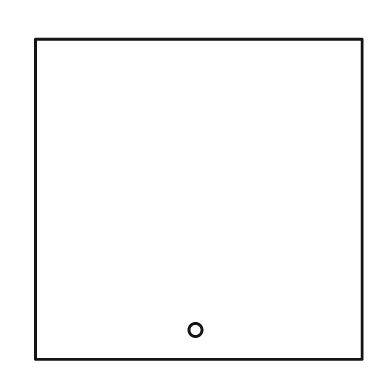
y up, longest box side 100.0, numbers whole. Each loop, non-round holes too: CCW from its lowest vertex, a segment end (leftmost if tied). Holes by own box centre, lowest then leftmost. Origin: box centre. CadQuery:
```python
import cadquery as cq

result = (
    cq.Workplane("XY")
    .moveTo(-50.0, -49.0)
    .lineTo(50.0, -49.0)
    .lineTo(50.0, 49.0)
    .lineTo(-50.0, 49.0)
    .close()
    .moveTo(-1.0, -40.0)
    .circle(2.0)
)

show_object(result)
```